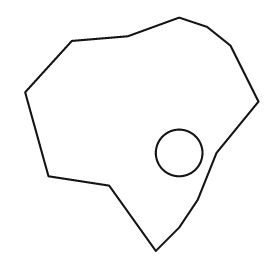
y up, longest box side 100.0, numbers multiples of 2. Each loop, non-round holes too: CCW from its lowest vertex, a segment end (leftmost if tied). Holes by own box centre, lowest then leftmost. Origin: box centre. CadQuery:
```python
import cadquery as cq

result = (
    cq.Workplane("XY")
    .moveTo(6.0, -50.0)
    .lineTo(16.0, -40.0)
    .lineTo(24.0, -28.0)
    .lineTo(32.0, -8.0)
    .lineTo(50.0, 14.0)
    .lineTo(38.0, 38.0)
    .lineTo(28.0, 46.0)
    .lineTo(16.0, 50.0)
    .lineTo(-6.0, 42.0)
    .lineTo(-30.0, 40.0)
    .lineTo(-50.0, 18.0)
    .lineTo(-40.0, -18.0)
    .lineTo(-14.0, -22.0)
    .close()
    .moveTo(16.0, -8.0)
    .circle(10.0)
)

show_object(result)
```